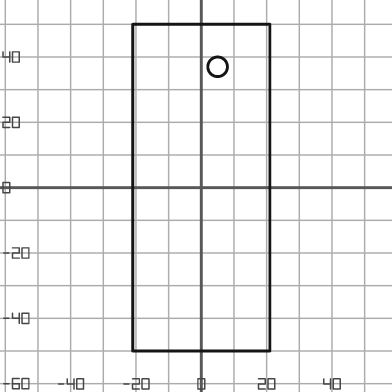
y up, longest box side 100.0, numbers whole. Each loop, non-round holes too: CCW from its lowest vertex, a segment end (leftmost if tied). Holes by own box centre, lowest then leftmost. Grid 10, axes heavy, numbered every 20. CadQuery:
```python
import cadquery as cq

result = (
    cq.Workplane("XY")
    .moveTo(-21.0, -50.0)
    .lineTo(21.0, -50.0)
    .lineTo(21.0, 50.0)
    .lineTo(-21.0, 50.0)
    .close()
    .moveTo(5.0, 37.0)
    .circle(3.0)
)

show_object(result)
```